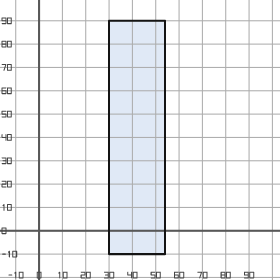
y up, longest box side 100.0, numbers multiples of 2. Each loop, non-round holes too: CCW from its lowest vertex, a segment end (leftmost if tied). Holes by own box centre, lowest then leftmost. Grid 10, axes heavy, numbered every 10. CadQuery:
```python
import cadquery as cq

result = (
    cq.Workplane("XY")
    .moveTo(30.0, -10.0)
    .lineTo(54.0, -10.0)
    .lineTo(54.0, 90.0)
    .lineTo(30.0, 90.0)
    .close()
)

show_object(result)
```